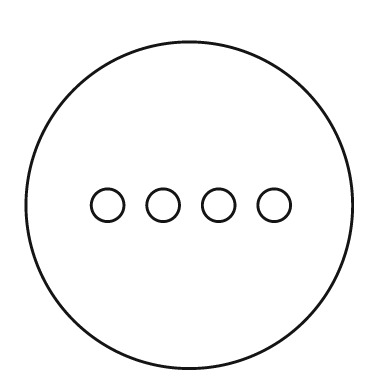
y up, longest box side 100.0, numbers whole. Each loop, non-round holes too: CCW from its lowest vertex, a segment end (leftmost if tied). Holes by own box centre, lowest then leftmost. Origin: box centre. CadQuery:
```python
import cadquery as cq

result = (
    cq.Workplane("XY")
    .moveTo(0.0, 0.0)
    .circle(50.0)
    .moveTo(-25.0, 0.0)
    .circle(5.0)
    .moveTo(-8.0, 0.0)
    .circle(5.0)
    .moveTo(9.0, 0.0)
    .circle(5.0)
    .moveTo(26.0, 0.0)
    .circle(5.0)
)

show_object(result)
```